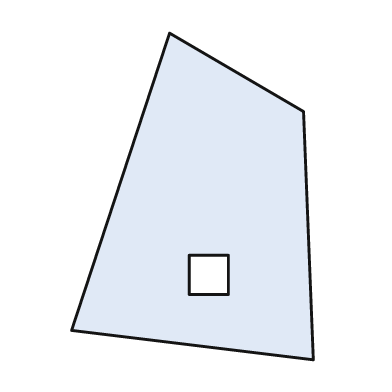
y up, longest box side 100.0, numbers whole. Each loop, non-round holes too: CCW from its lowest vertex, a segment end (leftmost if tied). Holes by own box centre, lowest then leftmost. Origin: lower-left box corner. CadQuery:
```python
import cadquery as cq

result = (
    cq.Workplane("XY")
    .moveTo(74.0, 0.0)
    .lineTo(71.0, 76.0)
    .lineTo(30.0, 100.0)
    .lineTo(0.0, 9.0)
    .close()
    .moveTo(36.0, 20.0)
    .lineTo(48.0, 20.0)
    .lineTo(48.0, 32.0)
    .lineTo(36.0, 32.0)
    .close()
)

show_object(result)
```